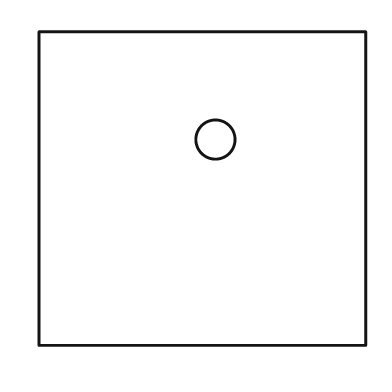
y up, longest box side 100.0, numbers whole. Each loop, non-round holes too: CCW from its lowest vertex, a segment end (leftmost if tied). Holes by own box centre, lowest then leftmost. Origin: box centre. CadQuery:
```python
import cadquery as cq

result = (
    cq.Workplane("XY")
    .moveTo(-50.0, -48.0)
    .lineTo(50.0, -48.0)
    .lineTo(50.0, 48.0)
    .lineTo(-50.0, 48.0)
    .close()
    .moveTo(4.0, 15.0)
    .circle(6.0)
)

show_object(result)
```